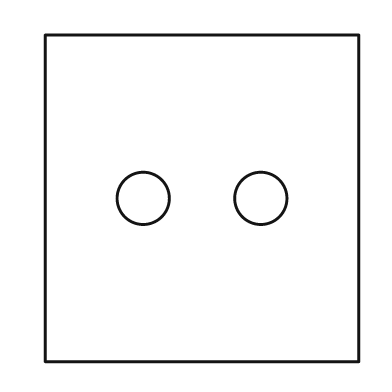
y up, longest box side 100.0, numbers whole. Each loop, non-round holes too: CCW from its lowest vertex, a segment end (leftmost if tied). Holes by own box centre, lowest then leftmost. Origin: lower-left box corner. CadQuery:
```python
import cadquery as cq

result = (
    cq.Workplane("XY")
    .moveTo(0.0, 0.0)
    .lineTo(96.0, 0.0)
    .lineTo(96.0, 100.0)
    .lineTo(0.0, 100.0)
    .close()
    .moveTo(30.0, 50.0)
    .circle(8.0)
    .moveTo(66.0, 50.0)
    .circle(8.0)
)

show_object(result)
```